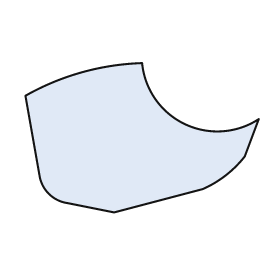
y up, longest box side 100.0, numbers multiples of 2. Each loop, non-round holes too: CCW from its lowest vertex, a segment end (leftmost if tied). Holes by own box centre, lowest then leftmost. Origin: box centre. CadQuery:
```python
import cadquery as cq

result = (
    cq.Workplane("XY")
    .moveTo(-12.0, -32.0)
    .lineTo(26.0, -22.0)
    .threePointArc((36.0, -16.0), (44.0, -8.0))
    .lineTo(50.0, 8.0)
    .threePointArc((18.0, 6.0), (0.0, 32.0))
    .threePointArc((-26.0, 28.0), (-50.0, 18.0))
    .lineTo(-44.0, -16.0)
    .threePointArc((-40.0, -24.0), (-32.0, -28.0))
    .close()
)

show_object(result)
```